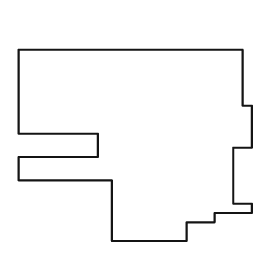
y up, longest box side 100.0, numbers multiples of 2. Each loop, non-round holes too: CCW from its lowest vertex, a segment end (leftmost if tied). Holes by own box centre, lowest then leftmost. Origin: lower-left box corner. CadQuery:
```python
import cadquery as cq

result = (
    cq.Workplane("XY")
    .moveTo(40.0, 0.0)
    .lineTo(72.0, 0.0)
    .lineTo(72.0, 8.0)
    .lineTo(84.0, 8.0)
    .lineTo(84.0, 12.0)
    .lineTo(100.0, 12.0)
    .lineTo(100.0, 16.0)
    .lineTo(92.0, 16.0)
    .lineTo(92.0, 40.0)
    .lineTo(100.0, 40.0)
    .lineTo(100.0, 58.0)
    .lineTo(96.0, 58.0)
    .lineTo(96.0, 82.0)
    .lineTo(0.0, 82.0)
    .lineTo(0.0, 46.0)
    .lineTo(34.0, 46.0)
    .lineTo(34.0, 36.0)
    .lineTo(0.0, 36.0)
    .lineTo(0.0, 26.0)
    .lineTo(40.0, 26.0)
    .close()
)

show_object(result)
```